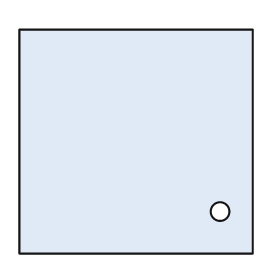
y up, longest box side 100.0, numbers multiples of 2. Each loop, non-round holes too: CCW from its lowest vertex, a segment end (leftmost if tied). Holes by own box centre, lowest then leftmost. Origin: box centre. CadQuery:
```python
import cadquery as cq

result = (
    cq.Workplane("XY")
    .moveTo(-50.0, -48.0)
    .lineTo(50.0, -48.0)
    .lineTo(50.0, 48.0)
    .lineTo(-50.0, 48.0)
    .close()
    .moveTo(36.0, -30.0)
    .circle(4.0)
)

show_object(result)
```